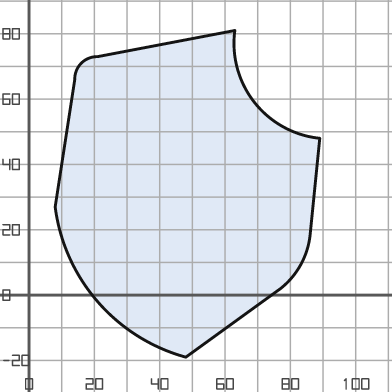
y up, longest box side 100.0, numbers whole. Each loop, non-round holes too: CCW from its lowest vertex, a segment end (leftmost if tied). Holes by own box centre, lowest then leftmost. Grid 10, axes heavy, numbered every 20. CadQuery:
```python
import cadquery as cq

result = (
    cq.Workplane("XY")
    .moveTo(48.0, -19.0)
    .lineTo(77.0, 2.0)
    .threePointArc((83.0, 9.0), (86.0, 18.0))
    .lineTo(89.0, 48.0)
    .threePointArc((69.0, 59.0), (63.0, 81.0))
    .lineTo(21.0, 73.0)
    .threePointArc((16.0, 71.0), (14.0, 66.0))
    .lineTo(8.0, 27.0)
    .threePointArc((21.0, -2.0), (48.0, -19.0))
    .close()
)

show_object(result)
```